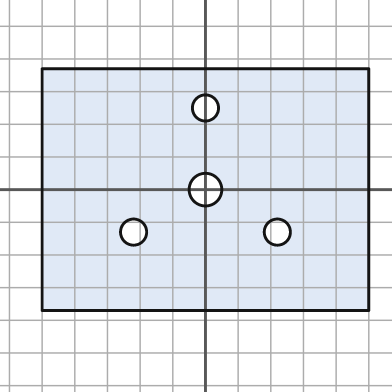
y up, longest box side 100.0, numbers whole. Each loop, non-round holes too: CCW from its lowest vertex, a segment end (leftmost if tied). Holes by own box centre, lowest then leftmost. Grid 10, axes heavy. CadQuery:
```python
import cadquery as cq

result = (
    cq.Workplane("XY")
    .moveTo(-50.0, -37.0)
    .lineTo(50.0, -37.0)
    .lineTo(50.0, 37.0)
    .lineTo(-50.0, 37.0)
    .close()
    .moveTo(-22.0, -13.0)
    .circle(4.0)
    .moveTo(22.0, -13.0)
    .circle(4.0)
    .moveTo(0.0, 0.0)
    .circle(5.0)
    .moveTo(0.0, 25.0)
    .circle(4.0)
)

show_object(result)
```